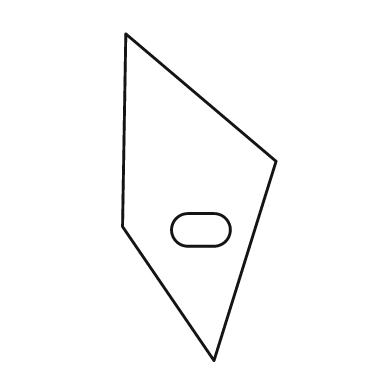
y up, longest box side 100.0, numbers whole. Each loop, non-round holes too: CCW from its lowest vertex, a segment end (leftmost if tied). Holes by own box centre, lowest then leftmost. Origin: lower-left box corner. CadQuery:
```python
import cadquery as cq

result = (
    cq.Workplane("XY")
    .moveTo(28.0, 0.0)
    .lineTo(47.0, 61.0)
    .lineTo(1.0, 100.0)
    .lineTo(0.0, 41.0)
    .close()
    .moveTo(20.0, 35.0)
    .lineTo(28.0, 35.0)
    .threePointArc((33.0, 40.0), (28.0, 45.0))
    .lineTo(20.0, 45.0)
    .threePointArc((15.0, 40.0), (20.0, 35.0))
    .close()
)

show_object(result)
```